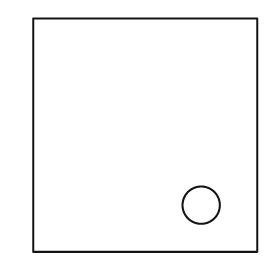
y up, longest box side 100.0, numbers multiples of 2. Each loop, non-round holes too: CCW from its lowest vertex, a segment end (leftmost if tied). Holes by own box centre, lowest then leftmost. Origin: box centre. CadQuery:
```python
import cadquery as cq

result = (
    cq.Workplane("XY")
    .moveTo(-48.0, -50.0)
    .lineTo(48.0, -50.0)
    .lineTo(48.0, 50.0)
    .lineTo(-48.0, 50.0)
    .close()
    .moveTo(24.0, -30.0)
    .circle(8.0)
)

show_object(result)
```